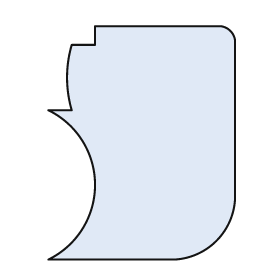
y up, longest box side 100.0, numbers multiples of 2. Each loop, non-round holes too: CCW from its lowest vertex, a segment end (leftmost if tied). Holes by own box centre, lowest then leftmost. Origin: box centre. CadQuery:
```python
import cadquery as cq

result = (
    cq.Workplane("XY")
    .moveTo(-40.0, -50.0)
    .lineTo(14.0, -50.0)
    .threePointArc((32.0, -42.0), (40.0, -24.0))
    .lineTo(40.0, 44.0)
    .threePointArc((38.0, 48.0), (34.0, 50.0))
    .lineTo(-20.0, 50.0)
    .lineTo(-20.0, 42.0)
    .lineTo(-30.0, 42.0)
    .threePointArc((-32.0, 28.0), (-30.0, 14.0))
    .lineTo(-40.0, 14.0)
    .threePointArc((-20.0, -18.0), (-40.0, -50.0))
    .close()
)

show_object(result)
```